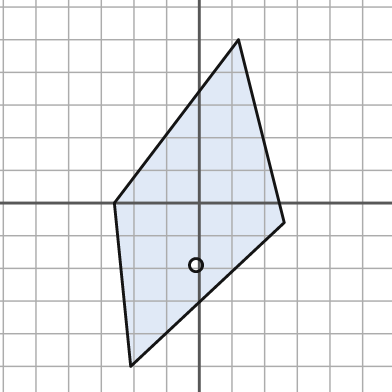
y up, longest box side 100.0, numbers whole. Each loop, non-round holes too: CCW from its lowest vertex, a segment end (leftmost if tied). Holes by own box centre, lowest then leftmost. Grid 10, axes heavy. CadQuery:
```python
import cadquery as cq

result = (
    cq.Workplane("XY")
    .moveTo(-21.0, -50.0)
    .lineTo(26.0, -6.0)
    .lineTo(12.0, 50.0)
    .lineTo(-26.0, 0.0)
    .close()
    .moveTo(-1.0, -19.0)
    .circle(2.0)
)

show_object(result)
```